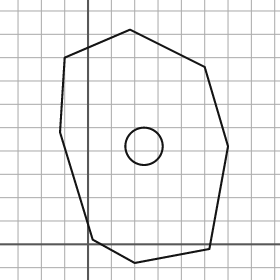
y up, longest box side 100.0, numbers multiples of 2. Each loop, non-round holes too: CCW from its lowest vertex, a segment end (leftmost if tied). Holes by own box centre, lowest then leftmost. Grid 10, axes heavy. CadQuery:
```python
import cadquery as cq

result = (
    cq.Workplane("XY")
    .moveTo(20.0, -8.0)
    .lineTo(52.0, -2.0)
    .lineTo(60.0, 42.0)
    .lineTo(50.0, 76.0)
    .lineTo(18.0, 92.0)
    .lineTo(-10.0, 80.0)
    .lineTo(-12.0, 48.0)
    .lineTo(2.0, 2.0)
    .close()
    .moveTo(24.0, 42.0)
    .circle(8.0)
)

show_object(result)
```